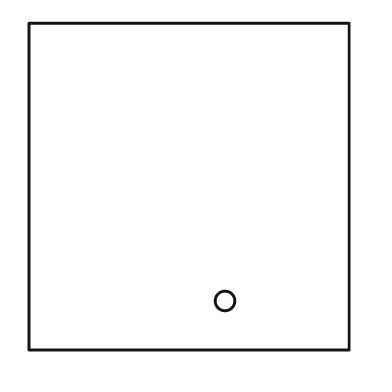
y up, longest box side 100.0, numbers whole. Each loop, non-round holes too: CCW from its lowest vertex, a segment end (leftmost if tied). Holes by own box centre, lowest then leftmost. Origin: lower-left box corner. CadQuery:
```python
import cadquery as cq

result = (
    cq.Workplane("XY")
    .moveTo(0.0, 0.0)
    .lineTo(98.0, 0.0)
    .lineTo(98.0, 100.0)
    .lineTo(0.0, 100.0)
    .close()
    .moveTo(60.0, 15.0)
    .circle(3.0)
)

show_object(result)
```